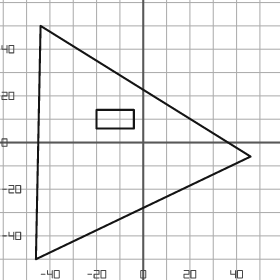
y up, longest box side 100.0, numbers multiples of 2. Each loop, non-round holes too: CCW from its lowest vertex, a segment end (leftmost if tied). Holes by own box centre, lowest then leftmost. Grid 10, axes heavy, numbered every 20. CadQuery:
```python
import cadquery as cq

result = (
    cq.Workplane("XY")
    .moveTo(-46.0, -50.0)
    .lineTo(46.0, -6.0)
    .lineTo(-44.0, 50.0)
    .close()
    .moveTo(-20.0, 6.0)
    .lineTo(-4.0, 6.0)
    .lineTo(-4.0, 14.0)
    .lineTo(-20.0, 14.0)
    .close()
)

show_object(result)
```